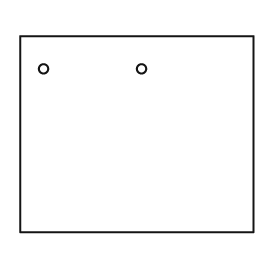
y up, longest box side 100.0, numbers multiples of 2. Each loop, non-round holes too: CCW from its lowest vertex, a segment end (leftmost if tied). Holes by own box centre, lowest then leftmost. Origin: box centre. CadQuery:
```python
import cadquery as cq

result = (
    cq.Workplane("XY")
    .moveTo(-50.0, -42.0)
    .lineTo(50.0, -42.0)
    .lineTo(50.0, 42.0)
    .lineTo(-50.0, 42.0)
    .close()
    .moveTo(-40.0, 28.0)
    .circle(2.0)
    .moveTo(2.0, 28.0)
    .circle(2.0)
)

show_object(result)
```